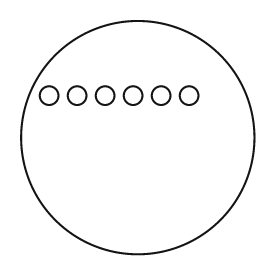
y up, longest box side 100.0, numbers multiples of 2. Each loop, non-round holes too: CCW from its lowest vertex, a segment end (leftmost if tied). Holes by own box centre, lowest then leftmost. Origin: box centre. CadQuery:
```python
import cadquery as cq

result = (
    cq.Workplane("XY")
    .moveTo(0.0, 0.0)
    .circle(50.0)
    .moveTo(-38.0, 18.0)
    .circle(4.0)
    .moveTo(-26.0, 18.0)
    .circle(4.0)
    .moveTo(-14.0, 18.0)
    .circle(4.0)
    .moveTo(-2.0, 18.0)
    .circle(4.0)
    .moveTo(10.0, 18.0)
    .circle(4.0)
    .moveTo(22.0, 18.0)
    .circle(4.0)
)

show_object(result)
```